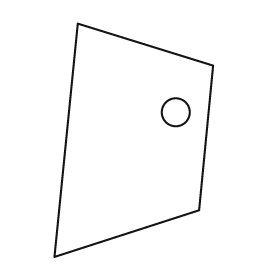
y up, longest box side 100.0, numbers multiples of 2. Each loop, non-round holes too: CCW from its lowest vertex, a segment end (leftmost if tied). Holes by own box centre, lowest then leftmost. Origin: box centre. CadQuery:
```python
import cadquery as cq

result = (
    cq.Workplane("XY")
    .moveTo(-34.0, -50.0)
    .lineTo(28.0, -30.0)
    .lineTo(34.0, 32.0)
    .lineTo(-24.0, 50.0)
    .close()
    .moveTo(18.0, 12.0)
    .circle(6.0)
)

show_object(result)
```